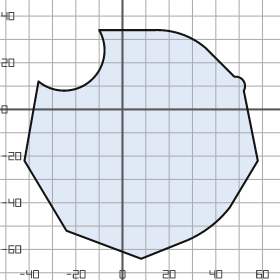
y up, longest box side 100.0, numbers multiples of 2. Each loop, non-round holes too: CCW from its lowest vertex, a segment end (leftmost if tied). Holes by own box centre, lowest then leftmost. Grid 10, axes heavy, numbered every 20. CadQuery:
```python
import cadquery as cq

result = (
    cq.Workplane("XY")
    .moveTo(8.0, -64.0)
    .lineTo(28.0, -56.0)
    .threePointArc((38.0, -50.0), (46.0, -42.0))
    .lineTo(58.0, -22.0)
    .lineTo(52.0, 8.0)
    .threePointArc((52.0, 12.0), (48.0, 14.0))
    .lineTo(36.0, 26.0)
    .threePointArc((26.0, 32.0), (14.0, 34.0))
    .lineTo(-10.0, 34.0)
    .threePointArc((-14.0, 12.0), (-36.0, 12.0))
    .lineTo(-42.0, -22.0)
    .lineTo(-24.0, -52.0)
    .close()
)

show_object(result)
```